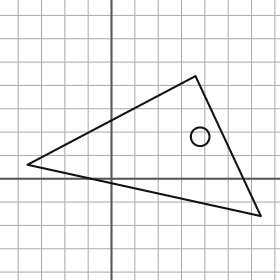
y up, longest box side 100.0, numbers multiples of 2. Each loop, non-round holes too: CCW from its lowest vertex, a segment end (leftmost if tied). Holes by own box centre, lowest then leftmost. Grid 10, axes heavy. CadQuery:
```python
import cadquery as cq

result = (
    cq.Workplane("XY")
    .moveTo(64.0, -16.0)
    .lineTo(36.0, 44.0)
    .lineTo(-36.0, 6.0)
    .close()
    .moveTo(38.0, 18.0)
    .circle(4.0)
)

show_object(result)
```